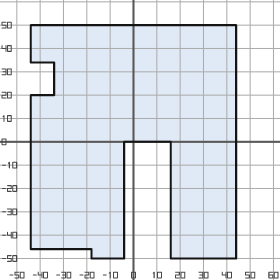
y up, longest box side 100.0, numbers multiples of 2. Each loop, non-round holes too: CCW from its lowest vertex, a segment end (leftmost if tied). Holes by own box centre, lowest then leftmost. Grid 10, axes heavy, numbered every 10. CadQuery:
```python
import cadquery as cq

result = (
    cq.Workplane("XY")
    .moveTo(-18.0, -50.0)
    .lineTo(-4.0, -50.0)
    .lineTo(-4.0, 0.0)
    .lineTo(16.0, 0.0)
    .lineTo(16.0, -50.0)
    .lineTo(44.0, -50.0)
    .lineTo(44.0, 50.0)
    .lineTo(-44.0, 50.0)
    .lineTo(-44.0, 34.0)
    .lineTo(-34.0, 34.0)
    .lineTo(-34.0, 20.0)
    .lineTo(-44.0, 20.0)
    .lineTo(-44.0, -46.0)
    .lineTo(-18.0, -46.0)
    .close()
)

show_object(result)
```